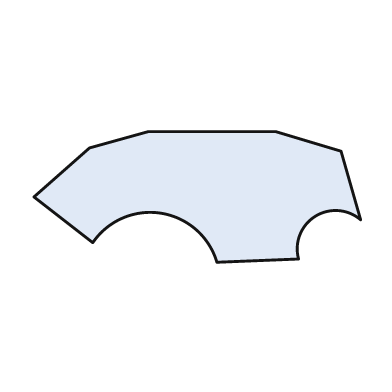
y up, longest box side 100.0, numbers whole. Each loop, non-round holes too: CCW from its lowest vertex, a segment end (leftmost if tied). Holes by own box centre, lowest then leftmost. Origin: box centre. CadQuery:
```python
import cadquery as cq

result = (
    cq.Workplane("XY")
    .moveTo(6.0, -20.0)
    .lineTo(31.0, -19.0)
    .threePointArc((36.0, -6.0), (50.0, -7.0))
    .lineTo(44.0, 14.0)
    .lineTo(24.0, 20.0)
    .lineTo(-15.0, 20.0)
    .lineTo(-33.0, 15.0)
    .lineTo(-50.0, 0.0)
    .lineTo(-32.0, -14.0)
    .threePointArc((-11.0, -5.0), (6.0, -20.0))
    .close()
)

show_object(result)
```